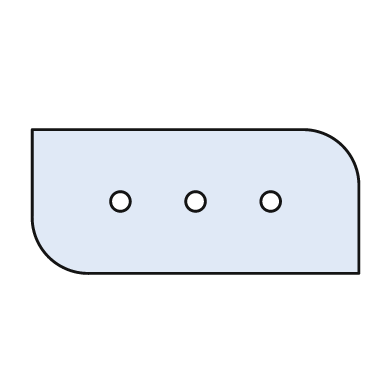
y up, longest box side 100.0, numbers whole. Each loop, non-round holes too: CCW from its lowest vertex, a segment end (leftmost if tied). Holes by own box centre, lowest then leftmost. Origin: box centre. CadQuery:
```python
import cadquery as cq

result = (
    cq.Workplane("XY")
    .moveTo(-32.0, -22.0)
    .lineTo(50.0, -22.0)
    .lineTo(50.0, 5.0)
    .threePointArc((45.0, 17.0), (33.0, 22.0))
    .lineTo(-50.0, 22.0)
    .lineTo(-50.0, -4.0)
    .threePointArc((-45.0, -17.0), (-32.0, -22.0))
    .close()
    .moveTo(-23.0, 0.0)
    .circle(3.0)
    .moveTo(0.0, 0.0)
    .circle(3.0)
    .moveTo(23.0, 0.0)
    .circle(3.0)
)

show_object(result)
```